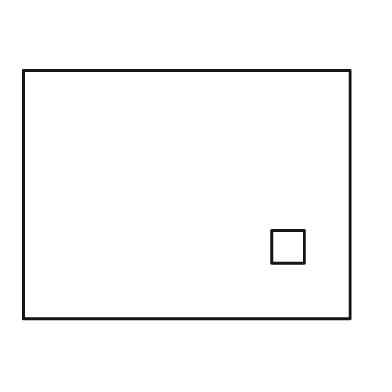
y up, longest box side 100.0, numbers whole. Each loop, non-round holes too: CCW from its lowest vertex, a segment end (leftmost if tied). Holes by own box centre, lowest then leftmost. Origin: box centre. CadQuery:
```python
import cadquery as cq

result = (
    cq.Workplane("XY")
    .moveTo(-50.0, -38.0)
    .lineTo(50.0, -38.0)
    .lineTo(50.0, 38.0)
    .lineTo(-50.0, 38.0)
    .close()
    .moveTo(26.0, -21.0)
    .lineTo(36.0, -21.0)
    .lineTo(36.0, -11.0)
    .lineTo(26.0, -11.0)
    .close()
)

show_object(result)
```